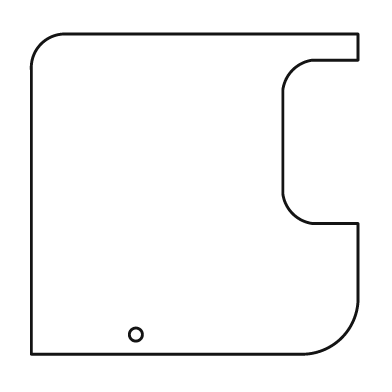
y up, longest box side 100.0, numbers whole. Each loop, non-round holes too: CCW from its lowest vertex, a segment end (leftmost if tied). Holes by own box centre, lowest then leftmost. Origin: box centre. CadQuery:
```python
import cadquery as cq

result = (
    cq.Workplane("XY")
    .moveTo(-50.0, -49.0)
    .lineTo(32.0, -49.0)
    .threePointArc((45.0, -44.0), (50.0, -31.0))
    .lineTo(50.0, -9.0)
    .lineTo(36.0, -9.0)
    .threePointArc((30.0, -6.0), (27.0, 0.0))
    .lineTo(27.0, 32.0)
    .threePointArc((30.0, 38.0), (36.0, 41.0))
    .lineTo(50.0, 41.0)
    .lineTo(50.0, 49.0)
    .lineTo(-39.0, 49.0)
    .threePointArc((-47.0, 46.0), (-50.0, 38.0))
    .close()
    .moveTo(-18.0, -43.0)
    .circle(2.0)
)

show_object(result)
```